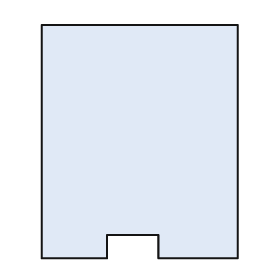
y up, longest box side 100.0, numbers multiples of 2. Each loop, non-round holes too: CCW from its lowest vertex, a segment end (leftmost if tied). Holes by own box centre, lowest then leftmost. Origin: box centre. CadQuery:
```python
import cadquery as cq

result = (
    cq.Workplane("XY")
    .moveTo(-42.0, -50.0)
    .lineTo(-14.0, -50.0)
    .lineTo(-14.0, -40.0)
    .lineTo(8.0, -40.0)
    .lineTo(8.0, -50.0)
    .lineTo(42.0, -50.0)
    .lineTo(42.0, 50.0)
    .lineTo(-42.0, 50.0)
    .close()
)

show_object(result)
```